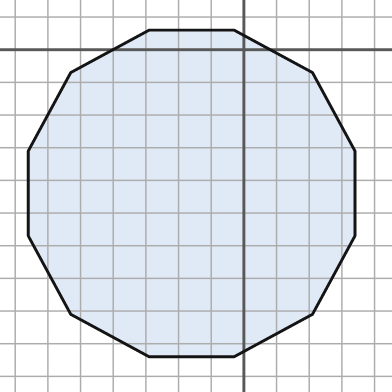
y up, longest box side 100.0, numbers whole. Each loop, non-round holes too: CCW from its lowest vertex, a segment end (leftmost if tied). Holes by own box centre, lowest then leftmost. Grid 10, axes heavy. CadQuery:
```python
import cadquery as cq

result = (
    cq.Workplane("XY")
    .moveTo(-29.0, -94.0)
    .lineTo(-3.0, -94.0)
    .lineTo(21.0, -81.0)
    .lineTo(34.0, -57.0)
    .lineTo(34.0, -31.0)
    .lineTo(21.0, -7.0)
    .lineTo(-3.0, 6.0)
    .lineTo(-29.0, 6.0)
    .lineTo(-53.0, -7.0)
    .lineTo(-66.0, -31.0)
    .lineTo(-66.0, -57.0)
    .lineTo(-53.0, -81.0)
    .close()
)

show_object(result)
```